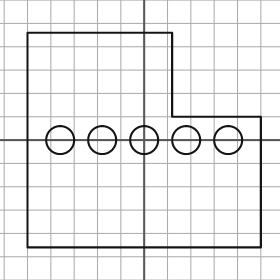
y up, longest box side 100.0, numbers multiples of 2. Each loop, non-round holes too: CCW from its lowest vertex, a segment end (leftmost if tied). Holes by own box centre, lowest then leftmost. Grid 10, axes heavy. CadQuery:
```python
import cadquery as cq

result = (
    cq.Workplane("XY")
    .moveTo(-50.0, -46.0)
    .lineTo(50.0, -46.0)
    .lineTo(50.0, 10.0)
    .lineTo(12.0, 10.0)
    .lineTo(12.0, 46.0)
    .lineTo(-50.0, 46.0)
    .close()
    .moveTo(-36.0, 0.0)
    .circle(6.0)
    .moveTo(-18.0, 0.0)
    .circle(6.0)
    .moveTo(0.0, 0.0)
    .circle(6.0)
    .moveTo(18.0, 0.0)
    .circle(6.0)
    .moveTo(36.0, 0.0)
    .circle(6.0)
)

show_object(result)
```